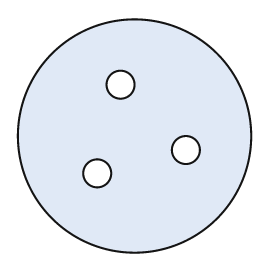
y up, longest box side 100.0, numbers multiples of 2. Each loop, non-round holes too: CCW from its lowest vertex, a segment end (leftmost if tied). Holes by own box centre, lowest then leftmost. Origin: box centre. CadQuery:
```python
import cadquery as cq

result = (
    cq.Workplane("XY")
    .moveTo(0.0, 0.0)
    .circle(50.0)
    .moveTo(-16.0, -16.0)
    .circle(6.0)
    .moveTo(22.0, -6.0)
    .circle(6.0)
    .moveTo(-6.0, 22.0)
    .circle(6.0)
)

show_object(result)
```